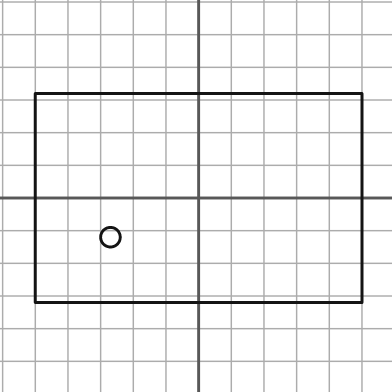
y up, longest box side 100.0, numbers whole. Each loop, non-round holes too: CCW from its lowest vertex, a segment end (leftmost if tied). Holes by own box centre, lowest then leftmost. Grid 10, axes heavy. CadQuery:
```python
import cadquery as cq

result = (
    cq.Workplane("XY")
    .moveTo(-50.0, -32.0)
    .lineTo(50.0, -32.0)
    .lineTo(50.0, 32.0)
    .lineTo(-50.0, 32.0)
    .close()
    .moveTo(-27.0, -12.0)
    .circle(3.0)
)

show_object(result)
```